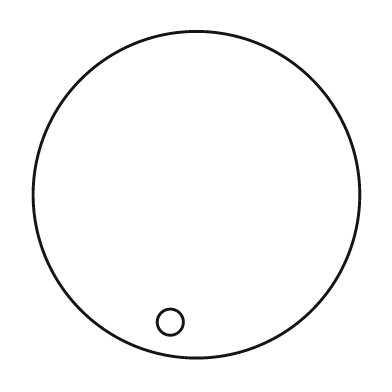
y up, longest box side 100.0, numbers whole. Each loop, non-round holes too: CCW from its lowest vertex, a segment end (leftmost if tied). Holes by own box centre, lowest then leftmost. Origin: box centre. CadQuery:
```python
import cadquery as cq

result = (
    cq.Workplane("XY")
    .moveTo(0.0, 0.0)
    .circle(50.0)
    .moveTo(-8.0, -39.0)
    .circle(4.0)
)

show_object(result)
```